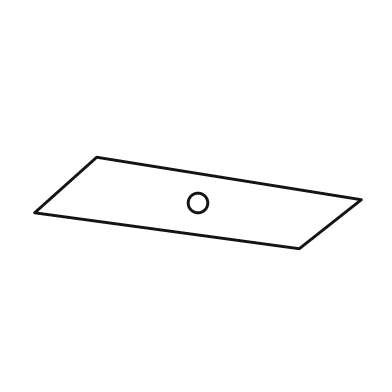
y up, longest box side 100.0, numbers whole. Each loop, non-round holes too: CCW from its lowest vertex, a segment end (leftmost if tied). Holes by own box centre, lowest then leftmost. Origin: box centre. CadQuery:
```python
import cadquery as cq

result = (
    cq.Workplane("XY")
    .moveTo(31.0, -14.0)
    .lineTo(50.0, 1.0)
    .lineTo(-31.0, 14.0)
    .lineTo(-50.0, -3.0)
    .close()
    .moveTo(0.0, 0.0)
    .circle(3.0)
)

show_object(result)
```